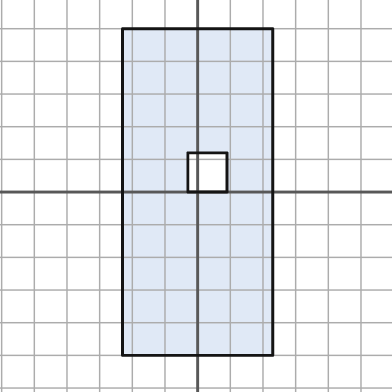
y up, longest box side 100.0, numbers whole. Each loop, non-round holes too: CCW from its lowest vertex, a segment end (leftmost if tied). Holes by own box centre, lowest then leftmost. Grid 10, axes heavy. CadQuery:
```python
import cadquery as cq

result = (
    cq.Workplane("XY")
    .moveTo(-23.0, -50.0)
    .lineTo(23.0, -50.0)
    .lineTo(23.0, 50.0)
    .lineTo(-23.0, 50.0)
    .close()
    .moveTo(-3.0, 0.0)
    .lineTo(9.0, 0.0)
    .lineTo(9.0, 12.0)
    .lineTo(-3.0, 12.0)
    .close()
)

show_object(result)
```